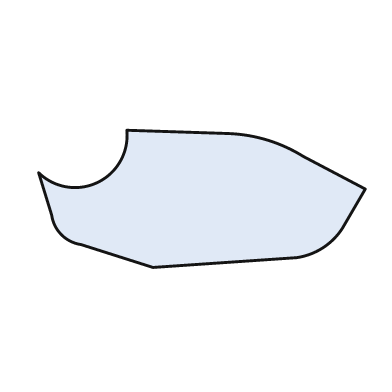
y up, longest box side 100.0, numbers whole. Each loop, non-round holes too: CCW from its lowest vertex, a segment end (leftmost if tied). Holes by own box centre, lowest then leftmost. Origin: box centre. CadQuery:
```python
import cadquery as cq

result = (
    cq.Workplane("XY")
    .moveTo(-15.0, -21.0)
    .lineTo(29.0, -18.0)
    .threePointArc((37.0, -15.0), (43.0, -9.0))
    .lineTo(50.0, 3.0)
    .lineTo(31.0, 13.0)
    .threePointArc((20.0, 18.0), (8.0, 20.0))
    .lineTo(-23.0, 21.0)
    .threePointArc((-32.0, 5.0), (-50.0, 8.0))
    .lineTo(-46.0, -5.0)
    .threePointArc((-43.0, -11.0), (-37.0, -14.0))
    .close()
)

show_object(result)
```